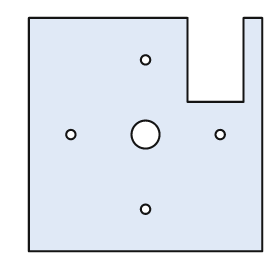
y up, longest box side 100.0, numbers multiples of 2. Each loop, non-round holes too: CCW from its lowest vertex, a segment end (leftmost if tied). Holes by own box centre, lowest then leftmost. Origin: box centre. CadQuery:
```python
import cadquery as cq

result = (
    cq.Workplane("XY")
    .moveTo(-50.0, -50.0)
    .lineTo(50.0, -50.0)
    .lineTo(50.0, 50.0)
    .lineTo(42.0, 50.0)
    .lineTo(42.0, 14.0)
    .lineTo(18.0, 14.0)
    .lineTo(18.0, 50.0)
    .lineTo(-50.0, 50.0)
    .close()
    .moveTo(0.0, -32.0)
    .circle(2.0)
    .moveTo(-32.0, 0.0)
    .circle(2.0)
    .moveTo(0.0, 0.0)
    .circle(6.0)
    .moveTo(32.0, 0.0)
    .circle(2.0)
    .moveTo(0.0, 32.0)
    .circle(2.0)
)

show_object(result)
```